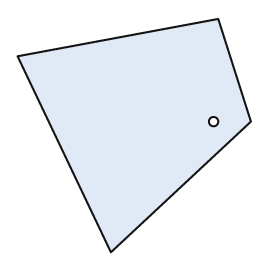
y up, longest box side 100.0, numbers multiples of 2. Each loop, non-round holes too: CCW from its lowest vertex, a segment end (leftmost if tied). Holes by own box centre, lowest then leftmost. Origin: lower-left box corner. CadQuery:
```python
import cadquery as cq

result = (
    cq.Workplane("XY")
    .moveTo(40.0, 0.0)
    .lineTo(100.0, 56.0)
    .lineTo(86.0, 100.0)
    .lineTo(0.0, 84.0)
    .close()
    .moveTo(84.0, 56.0)
    .circle(2.0)
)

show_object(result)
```